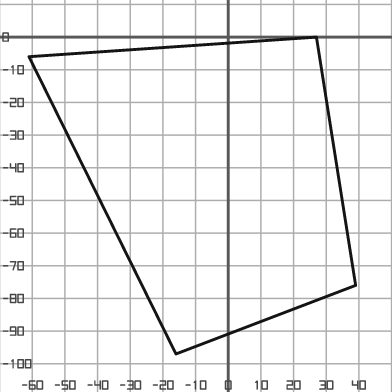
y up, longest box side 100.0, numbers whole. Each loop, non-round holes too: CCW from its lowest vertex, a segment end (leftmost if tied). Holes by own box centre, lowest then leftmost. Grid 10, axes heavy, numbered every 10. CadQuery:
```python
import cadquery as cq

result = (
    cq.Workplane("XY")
    .moveTo(-16.0, -97.0)
    .lineTo(39.0, -76.0)
    .lineTo(27.0, 0.0)
    .lineTo(-61.0, -6.0)
    .close()
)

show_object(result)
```